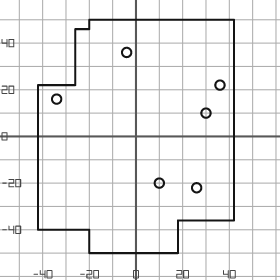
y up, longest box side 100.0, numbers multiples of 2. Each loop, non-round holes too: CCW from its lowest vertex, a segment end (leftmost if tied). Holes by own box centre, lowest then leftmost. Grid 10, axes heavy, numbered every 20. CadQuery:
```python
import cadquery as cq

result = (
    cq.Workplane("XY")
    .moveTo(-20.0, -50.0)
    .lineTo(18.0, -50.0)
    .lineTo(18.0, -36.0)
    .lineTo(42.0, -36.0)
    .lineTo(42.0, 50.0)
    .lineTo(-20.0, 50.0)
    .lineTo(-20.0, 46.0)
    .lineTo(-26.0, 46.0)
    .lineTo(-26.0, 22.0)
    .lineTo(-42.0, 22.0)
    .lineTo(-42.0, -40.0)
    .lineTo(-20.0, -40.0)
    .close()
    .moveTo(26.0, -22.0)
    .circle(2.0)
    .moveTo(10.0, -20.0)
    .circle(2.0)
    .moveTo(30.0, 10.0)
    .circle(2.0)
    .moveTo(-34.0, 16.0)
    .circle(2.0)
    .moveTo(36.0, 22.0)
    .circle(2.0)
    .moveTo(-4.0, 36.0)
    .circle(2.0)
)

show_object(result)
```